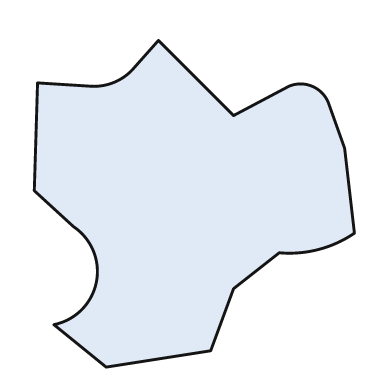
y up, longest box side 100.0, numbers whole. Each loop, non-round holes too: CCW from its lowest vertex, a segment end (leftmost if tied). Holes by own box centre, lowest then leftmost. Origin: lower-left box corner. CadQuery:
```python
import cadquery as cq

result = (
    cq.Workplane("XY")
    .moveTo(22.0, 0.0)
    .lineTo(54.0, 5.0)
    .lineTo(61.0, 24.0)
    .lineTo(75.0, 35.0)
    .threePointArc((87.0, 36.0), (98.0, 41.0))
    .lineTo(95.0, 67.0)
    .lineTo(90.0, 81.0)
    .threePointArc((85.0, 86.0), (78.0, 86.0))
    .lineTo(61.0, 77.0)
    .lineTo(38.0, 100.0)
    .lineTo(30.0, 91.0)
    .threePointArc((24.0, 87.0), (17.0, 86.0))
    .lineTo(1.0, 87.0)
    .lineTo(0.0, 54.0)
    .lineTo(12.0, 43.0)
    .threePointArc((19.0, 26.0), (6.0, 13.0))
    .close()
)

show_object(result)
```